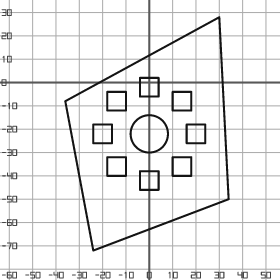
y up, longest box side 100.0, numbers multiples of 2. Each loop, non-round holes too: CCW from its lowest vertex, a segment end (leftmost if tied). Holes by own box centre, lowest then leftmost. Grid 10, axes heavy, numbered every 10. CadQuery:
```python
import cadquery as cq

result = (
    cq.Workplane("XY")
    .moveTo(-24.0, -72.0)
    .lineTo(34.0, -50.0)
    .lineTo(30.0, 28.0)
    .lineTo(-36.0, -8.0)
    .close()
    .moveTo(-4.0, -46.0)
    .lineTo(4.0, -46.0)
    .lineTo(4.0, -38.0)
    .lineTo(-4.0, -38.0)
    .close()
    .moveTo(-18.0, -40.0)
    .lineTo(-10.0, -40.0)
    .lineTo(-10.0, -32.0)
    .lineTo(-18.0, -32.0)
    .close()
    .moveTo(10.0, -40.0)
    .lineTo(18.0, -40.0)
    .lineTo(18.0, -32.0)
    .lineTo(10.0, -32.0)
    .close()
    .moveTo(-24.0, -26.0)
    .lineTo(-16.0, -26.0)
    .lineTo(-16.0, -18.0)
    .lineTo(-24.0, -18.0)
    .close()
    .moveTo(0.0, -22.0)
    .circle(8.0)
    .moveTo(16.0, -26.0)
    .lineTo(24.0, -26.0)
    .lineTo(24.0, -18.0)
    .lineTo(16.0, -18.0)
    .close()
    .moveTo(-18.0, -12.0)
    .lineTo(-10.0, -12.0)
    .lineTo(-10.0, -4.0)
    .lineTo(-18.0, -4.0)
    .close()
    .moveTo(10.0, -12.0)
    .lineTo(18.0, -12.0)
    .lineTo(18.0, -4.0)
    .lineTo(10.0, -4.0)
    .close()
    .moveTo(-4.0, -6.0)
    .lineTo(4.0, -6.0)
    .lineTo(4.0, 2.0)
    .lineTo(-4.0, 2.0)
    .close()
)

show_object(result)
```